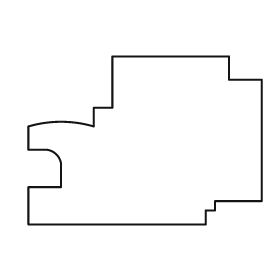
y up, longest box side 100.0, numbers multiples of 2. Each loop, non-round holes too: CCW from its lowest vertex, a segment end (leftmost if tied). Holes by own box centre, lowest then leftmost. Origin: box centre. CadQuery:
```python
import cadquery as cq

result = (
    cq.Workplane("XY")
    .moveTo(-50.0, -36.0)
    .lineTo(26.0, -36.0)
    .lineTo(26.0, -30.0)
    .lineTo(30.0, -30.0)
    .lineTo(30.0, -26.0)
    .lineTo(50.0, -26.0)
    .lineTo(50.0, 26.0)
    .lineTo(36.0, 26.0)
    .lineTo(36.0, 36.0)
    .lineTo(-14.0, 36.0)
    .lineTo(-14.0, 14.0)
    .lineTo(-22.0, 14.0)
    .lineTo(-22.0, 6.0)
    .threePointArc((-36.0, 8.0), (-50.0, 6.0))
    .lineTo(-50.0, -4.0)
    .lineTo(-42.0, -4.0)
    .threePointArc((-38.0, -6.0), (-36.0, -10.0))
    .lineTo(-36.0, -20.0)
    .lineTo(-50.0, -20.0)
    .close()
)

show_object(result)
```